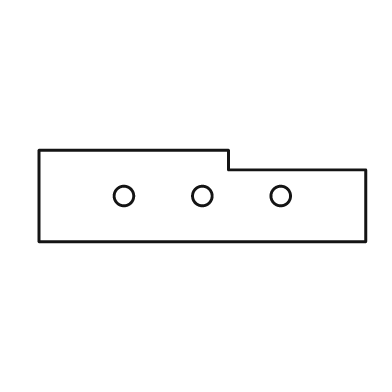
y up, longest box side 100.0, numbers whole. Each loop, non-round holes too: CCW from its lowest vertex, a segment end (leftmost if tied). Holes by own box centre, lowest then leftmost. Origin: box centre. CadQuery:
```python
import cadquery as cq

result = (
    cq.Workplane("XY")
    .moveTo(-50.0, -14.0)
    .lineTo(50.0, -14.0)
    .lineTo(50.0, 8.0)
    .lineTo(8.0, 8.0)
    .lineTo(8.0, 14.0)
    .lineTo(-50.0, 14.0)
    .close()
    .moveTo(-24.0, 0.0)
    .circle(3.0)
    .moveTo(0.0, 0.0)
    .circle(3.0)
    .moveTo(24.0, 0.0)
    .circle(3.0)
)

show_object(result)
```